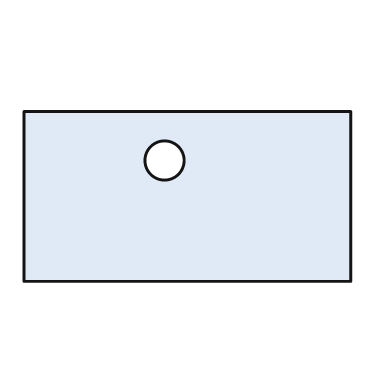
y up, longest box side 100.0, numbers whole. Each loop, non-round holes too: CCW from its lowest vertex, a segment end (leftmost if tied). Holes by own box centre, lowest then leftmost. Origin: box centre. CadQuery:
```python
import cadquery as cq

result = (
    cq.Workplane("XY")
    .moveTo(-50.0, -26.0)
    .lineTo(50.0, -26.0)
    .lineTo(50.0, 26.0)
    .lineTo(-50.0, 26.0)
    .close()
    .moveTo(-7.0, 11.0)
    .circle(6.0)
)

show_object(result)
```